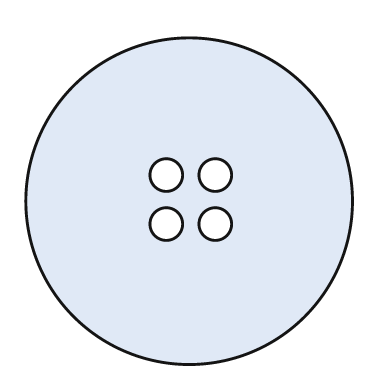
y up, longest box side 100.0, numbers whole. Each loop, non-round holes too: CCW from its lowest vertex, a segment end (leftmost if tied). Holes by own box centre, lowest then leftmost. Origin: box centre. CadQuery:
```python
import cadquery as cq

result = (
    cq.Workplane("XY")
    .moveTo(0.0, 0.0)
    .circle(50.0)
    .moveTo(-7.0, -7.0)
    .circle(5.0)
    .moveTo(8.0, -7.0)
    .circle(5.0)
    .moveTo(-7.0, 8.0)
    .circle(5.0)
    .moveTo(8.0, 8.0)
    .circle(5.0)
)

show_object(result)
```